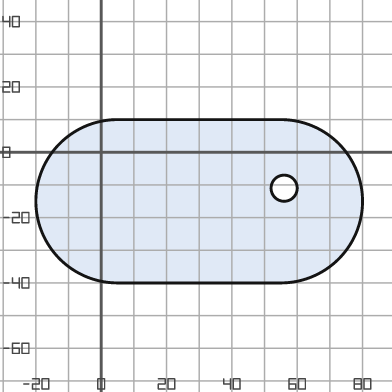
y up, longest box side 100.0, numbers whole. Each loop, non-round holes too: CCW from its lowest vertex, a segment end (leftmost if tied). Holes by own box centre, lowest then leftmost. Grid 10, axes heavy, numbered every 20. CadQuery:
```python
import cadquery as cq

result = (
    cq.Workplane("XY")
    .moveTo(5.0, -40.0)
    .lineTo(55.0, -40.0)
    .threePointArc((80.0, -15.0), (55.0, 10.0))
    .lineTo(5.0, 10.0)
    .threePointArc((-20.0, -15.0), (5.0, -40.0))
    .close()
    .moveTo(56.0, -11.0)
    .circle(4.0)
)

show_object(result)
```